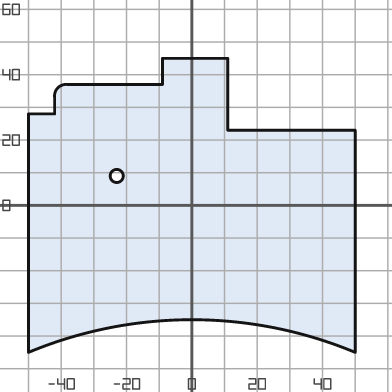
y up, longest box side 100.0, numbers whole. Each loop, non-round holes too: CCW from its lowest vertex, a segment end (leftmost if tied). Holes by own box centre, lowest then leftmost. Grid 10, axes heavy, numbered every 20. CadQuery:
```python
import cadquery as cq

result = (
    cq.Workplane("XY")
    .moveTo(-50.0, -45.0)
    .threePointArc((0.0, -35.0), (50.0, -45.0))
    .lineTo(50.0, 23.0)
    .lineTo(11.0, 23.0)
    .lineTo(11.0, 45.0)
    .lineTo(-9.0, 45.0)
    .lineTo(-9.0, 37.0)
    .lineTo(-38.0, 37.0)
    .threePointArc((-41.0, 36.0), (-42.0, 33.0))
    .lineTo(-42.0, 28.0)
    .lineTo(-50.0, 28.0)
    .close()
    .moveTo(-23.0, 9.0)
    .circle(2.0)
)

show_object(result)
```